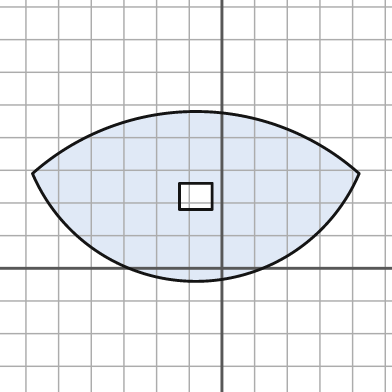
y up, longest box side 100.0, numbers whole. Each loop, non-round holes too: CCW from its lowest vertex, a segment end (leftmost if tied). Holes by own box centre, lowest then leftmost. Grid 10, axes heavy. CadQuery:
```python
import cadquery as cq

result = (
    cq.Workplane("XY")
    .moveTo(-58.0, 29.0)
    .threePointArc((-8.0, -4.0), (42.0, 29.0))
    .threePointArc((-8.0, 48.0), (-58.0, 29.0))
    .close()
    .moveTo(-13.0, 18.0)
    .lineTo(-3.0, 18.0)
    .lineTo(-3.0, 26.0)
    .lineTo(-13.0, 26.0)
    .close()
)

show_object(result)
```